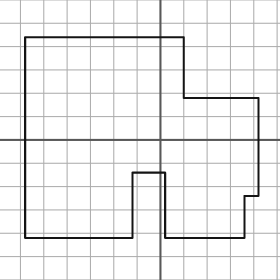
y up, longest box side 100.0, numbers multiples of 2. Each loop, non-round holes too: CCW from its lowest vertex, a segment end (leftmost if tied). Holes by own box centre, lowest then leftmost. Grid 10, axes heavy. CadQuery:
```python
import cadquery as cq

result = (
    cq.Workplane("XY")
    .moveTo(-58.0, -42.0)
    .lineTo(-12.0, -42.0)
    .lineTo(-12.0, -14.0)
    .lineTo(2.0, -14.0)
    .lineTo(2.0, -42.0)
    .lineTo(36.0, -42.0)
    .lineTo(36.0, -24.0)
    .lineTo(42.0, -24.0)
    .lineTo(42.0, 18.0)
    .lineTo(10.0, 18.0)
    .lineTo(10.0, 44.0)
    .lineTo(-58.0, 44.0)
    .close()
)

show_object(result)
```